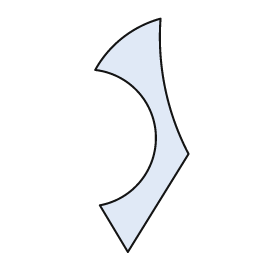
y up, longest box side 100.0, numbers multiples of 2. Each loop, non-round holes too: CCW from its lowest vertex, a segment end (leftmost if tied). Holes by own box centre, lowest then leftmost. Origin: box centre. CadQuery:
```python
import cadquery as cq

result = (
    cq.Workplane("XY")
    .moveTo(-6.0, -50.0)
    .lineTo(20.0, -8.0)
    .threePointArc((10.0, 20.0), (8.0, 50.0))
    .threePointArc((-8.0, 42.0), (-20.0, 28.0))
    .threePointArc((6.0, 0.0), (-18.0, -30.0))
    .close()
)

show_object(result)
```